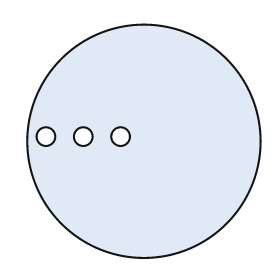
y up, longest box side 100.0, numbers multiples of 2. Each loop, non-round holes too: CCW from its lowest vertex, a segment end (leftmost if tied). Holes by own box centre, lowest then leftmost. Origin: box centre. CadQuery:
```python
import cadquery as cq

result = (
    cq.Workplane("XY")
    .moveTo(0.0, 0.0)
    .circle(50.0)
    .moveTo(-42.0, 2.0)
    .circle(4.0)
    .moveTo(-26.0, 2.0)
    .circle(4.0)
    .moveTo(-10.0, 2.0)
    .circle(4.0)
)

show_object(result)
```